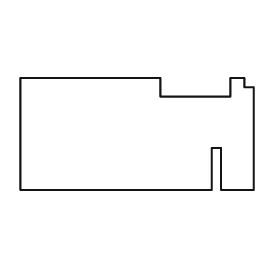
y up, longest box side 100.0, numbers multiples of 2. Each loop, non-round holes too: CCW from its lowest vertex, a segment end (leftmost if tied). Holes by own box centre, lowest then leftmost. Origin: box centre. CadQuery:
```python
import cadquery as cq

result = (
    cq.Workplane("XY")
    .moveTo(-50.0, -24.0)
    .lineTo(32.0, -24.0)
    .lineTo(32.0, -6.0)
    .lineTo(36.0, -6.0)
    .lineTo(36.0, -24.0)
    .lineTo(50.0, -24.0)
    .lineTo(50.0, 20.0)
    .lineTo(46.0, 20.0)
    .lineTo(46.0, 24.0)
    .lineTo(40.0, 24.0)
    .lineTo(40.0, 16.0)
    .lineTo(10.0, 16.0)
    .lineTo(10.0, 24.0)
    .lineTo(-50.0, 24.0)
    .close()
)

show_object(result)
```